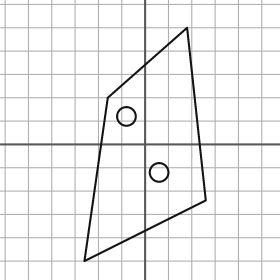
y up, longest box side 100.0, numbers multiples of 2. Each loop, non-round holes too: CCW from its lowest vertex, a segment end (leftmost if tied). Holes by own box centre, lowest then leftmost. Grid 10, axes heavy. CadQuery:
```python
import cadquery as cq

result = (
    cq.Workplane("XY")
    .moveTo(-26.0, -50.0)
    .lineTo(26.0, -24.0)
    .lineTo(18.0, 50.0)
    .lineTo(-16.0, 20.0)
    .close()
    .moveTo(6.0, -12.0)
    .circle(4.0)
    .moveTo(-8.0, 12.0)
    .circle(4.0)
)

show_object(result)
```